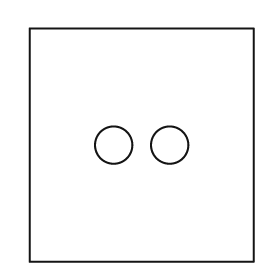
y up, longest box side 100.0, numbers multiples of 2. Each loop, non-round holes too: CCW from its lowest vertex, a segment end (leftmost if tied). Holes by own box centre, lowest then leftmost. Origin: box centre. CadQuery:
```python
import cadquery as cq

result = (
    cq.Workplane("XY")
    .moveTo(-48.0, -50.0)
    .lineTo(48.0, -50.0)
    .lineTo(48.0, 50.0)
    .lineTo(-48.0, 50.0)
    .close()
    .moveTo(-12.0, 0.0)
    .circle(8.0)
    .moveTo(12.0, 0.0)
    .circle(8.0)
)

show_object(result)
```